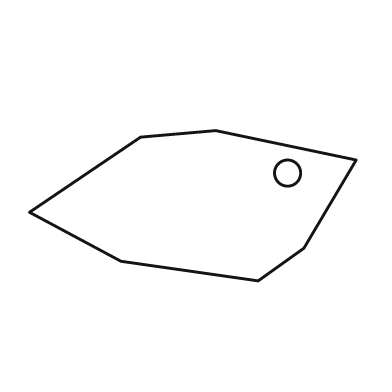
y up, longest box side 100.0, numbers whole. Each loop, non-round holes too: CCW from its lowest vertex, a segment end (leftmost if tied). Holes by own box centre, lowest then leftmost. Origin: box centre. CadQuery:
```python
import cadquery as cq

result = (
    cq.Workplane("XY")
    .moveTo(20.0, -23.0)
    .lineTo(34.0, -13.0)
    .lineTo(50.0, 14.0)
    .lineTo(7.0, 23.0)
    .lineTo(-16.0, 21.0)
    .lineTo(-50.0, -2.0)
    .lineTo(-22.0, -17.0)
    .close()
    .moveTo(29.0, 10.0)
    .circle(4.0)
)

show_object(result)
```